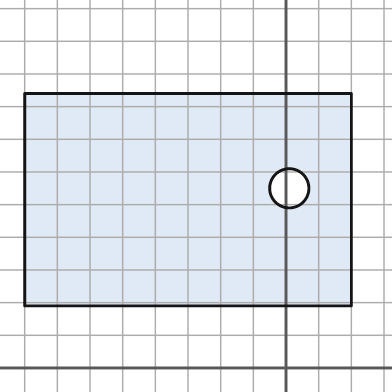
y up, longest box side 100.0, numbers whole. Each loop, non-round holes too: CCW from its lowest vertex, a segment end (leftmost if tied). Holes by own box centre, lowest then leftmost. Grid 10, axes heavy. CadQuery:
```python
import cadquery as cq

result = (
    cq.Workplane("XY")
    .moveTo(-80.0, 19.0)
    .lineTo(20.0, 19.0)
    .lineTo(20.0, 84.0)
    .lineTo(-80.0, 84.0)
    .close()
    .moveTo(1.0, 55.0)
    .circle(6.0)
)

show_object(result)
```